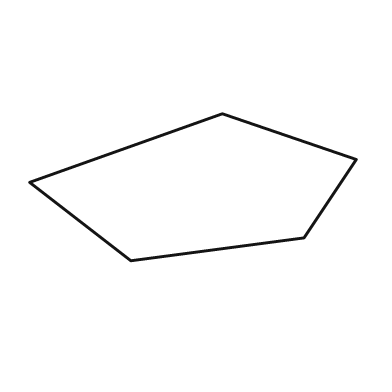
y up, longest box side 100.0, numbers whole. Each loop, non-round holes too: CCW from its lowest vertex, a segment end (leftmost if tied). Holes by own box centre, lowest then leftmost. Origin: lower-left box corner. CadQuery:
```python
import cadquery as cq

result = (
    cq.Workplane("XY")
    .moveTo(31.0, 0.0)
    .lineTo(84.0, 7.0)
    .lineTo(100.0, 31.0)
    .lineTo(59.0, 45.0)
    .lineTo(0.0, 24.0)
    .close()
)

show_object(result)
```